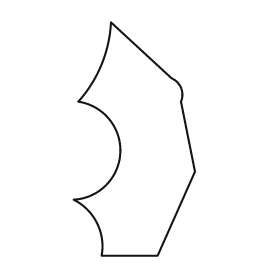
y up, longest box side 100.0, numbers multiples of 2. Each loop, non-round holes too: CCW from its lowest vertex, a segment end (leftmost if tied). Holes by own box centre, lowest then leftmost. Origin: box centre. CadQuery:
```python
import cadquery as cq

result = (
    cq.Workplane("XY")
    .moveTo(-14.0, -50.0)
    .lineTo(10.0, -50.0)
    .lineTo(26.0, -14.0)
    .lineTo(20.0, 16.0)
    .threePointArc((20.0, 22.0), (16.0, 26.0))
    .lineTo(-10.0, 50.0)
    .threePointArc((-14.0, 32.0), (-24.0, 16.0))
    .threePointArc((-6.0, -6.0), (-26.0, -26.0))
    .threePointArc((-16.0, -36.0), (-14.0, -50.0))
    .close()
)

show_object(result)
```